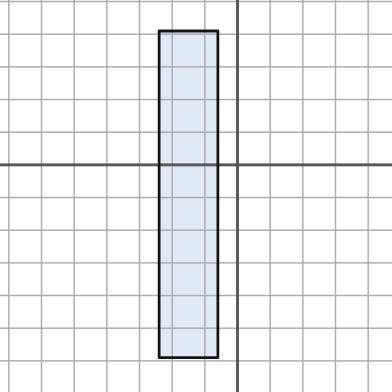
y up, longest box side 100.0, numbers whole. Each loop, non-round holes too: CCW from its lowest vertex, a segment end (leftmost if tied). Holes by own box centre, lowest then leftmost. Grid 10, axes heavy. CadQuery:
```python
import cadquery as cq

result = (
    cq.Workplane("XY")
    .moveTo(-24.0, -59.0)
    .lineTo(-6.0, -59.0)
    .lineTo(-6.0, 41.0)
    .lineTo(-24.0, 41.0)
    .close()
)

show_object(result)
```